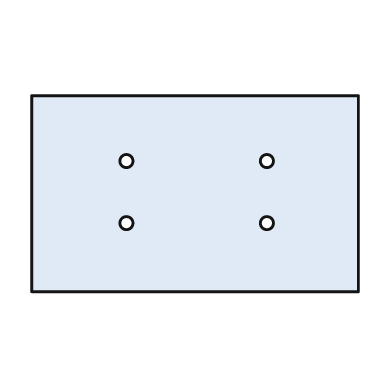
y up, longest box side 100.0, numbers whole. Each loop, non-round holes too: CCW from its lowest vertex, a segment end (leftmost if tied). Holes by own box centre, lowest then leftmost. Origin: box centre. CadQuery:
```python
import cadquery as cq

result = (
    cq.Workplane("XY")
    .moveTo(-50.0, -30.0)
    .lineTo(50.0, -30.0)
    .lineTo(50.0, 30.0)
    .lineTo(-50.0, 30.0)
    .close()
    .moveTo(-21.0, -9.0)
    .circle(2.0)
    .moveTo(22.0, -9.0)
    .circle(2.0)
    .moveTo(-21.0, 10.0)
    .circle(2.0)
    .moveTo(22.0, 10.0)
    .circle(2.0)
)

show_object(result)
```